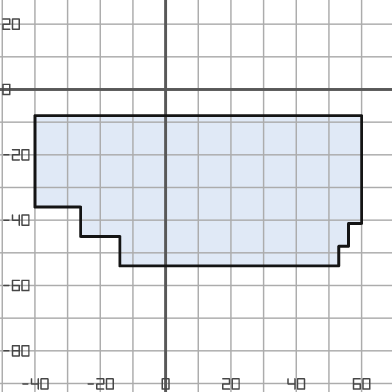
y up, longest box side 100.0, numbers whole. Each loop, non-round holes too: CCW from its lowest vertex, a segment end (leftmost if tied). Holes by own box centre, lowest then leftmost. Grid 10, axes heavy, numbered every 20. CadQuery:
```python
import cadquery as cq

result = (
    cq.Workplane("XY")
    .moveTo(-14.0, -54.0)
    .lineTo(53.0, -54.0)
    .lineTo(53.0, -48.0)
    .lineTo(56.0, -48.0)
    .lineTo(56.0, -41.0)
    .lineTo(60.0, -41.0)
    .lineTo(60.0, -8.0)
    .lineTo(-40.0, -8.0)
    .lineTo(-40.0, -36.0)
    .lineTo(-26.0, -36.0)
    .lineTo(-26.0, -45.0)
    .lineTo(-14.0, -45.0)
    .close()
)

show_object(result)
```